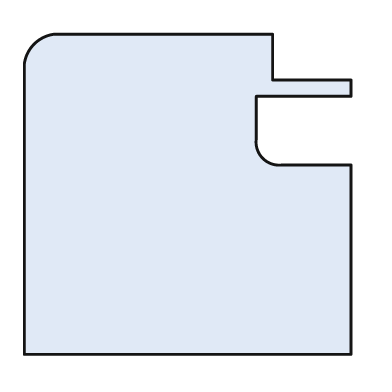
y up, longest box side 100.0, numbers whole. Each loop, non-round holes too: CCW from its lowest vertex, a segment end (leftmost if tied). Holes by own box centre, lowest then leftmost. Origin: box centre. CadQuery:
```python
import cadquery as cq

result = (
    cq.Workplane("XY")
    .moveTo(-50.0, -49.0)
    .lineTo(50.0, -49.0)
    .lineTo(50.0, 9.0)
    .lineTo(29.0, 9.0)
    .threePointArc((23.0, 11.0), (21.0, 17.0))
    .lineTo(21.0, 30.0)
    .lineTo(50.0, 30.0)
    .lineTo(50.0, 35.0)
    .lineTo(26.0, 35.0)
    .lineTo(26.0, 49.0)
    .lineTo(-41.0, 49.0)
    .threePointArc((-47.0, 46.0), (-50.0, 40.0))
    .close()
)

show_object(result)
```